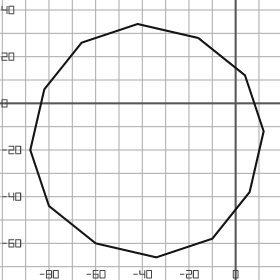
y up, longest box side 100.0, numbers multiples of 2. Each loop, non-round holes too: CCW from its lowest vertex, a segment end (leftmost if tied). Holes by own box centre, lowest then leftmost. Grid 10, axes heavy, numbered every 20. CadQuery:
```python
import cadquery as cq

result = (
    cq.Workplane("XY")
    .moveTo(-34.0, -66.0)
    .lineTo(-10.0, -58.0)
    .lineTo(6.0, -38.0)
    .lineTo(12.0, -12.0)
    .lineTo(4.0, 12.0)
    .lineTo(-16.0, 28.0)
    .lineTo(-42.0, 34.0)
    .lineTo(-66.0, 26.0)
    .lineTo(-82.0, 6.0)
    .lineTo(-88.0, -20.0)
    .lineTo(-80.0, -44.0)
    .lineTo(-60.0, -60.0)
    .close()
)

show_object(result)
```